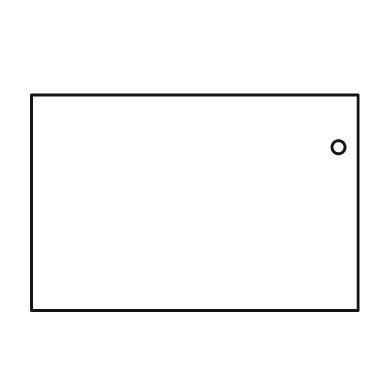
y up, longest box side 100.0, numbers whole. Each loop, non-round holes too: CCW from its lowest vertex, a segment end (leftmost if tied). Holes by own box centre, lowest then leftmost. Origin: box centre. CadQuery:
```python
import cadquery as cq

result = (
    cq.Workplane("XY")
    .moveTo(-50.0, -33.0)
    .lineTo(50.0, -33.0)
    .lineTo(50.0, 33.0)
    .lineTo(-50.0, 33.0)
    .close()
    .moveTo(44.0, 17.0)
    .circle(2.0)
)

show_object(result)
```